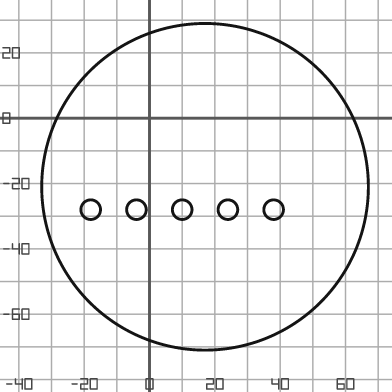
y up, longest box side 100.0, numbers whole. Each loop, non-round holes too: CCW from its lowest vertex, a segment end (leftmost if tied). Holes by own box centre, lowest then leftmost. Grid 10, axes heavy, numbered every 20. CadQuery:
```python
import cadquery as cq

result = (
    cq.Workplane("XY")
    .moveTo(17.0, -21.0)
    .circle(50.0)
    .moveTo(-18.0, -28.0)
    .circle(3.0)
    .moveTo(-4.0, -28.0)
    .circle(3.0)
    .moveTo(10.0, -28.0)
    .circle(3.0)
    .moveTo(24.0, -28.0)
    .circle(3.0)
    .moveTo(38.0, -28.0)
    .circle(3.0)
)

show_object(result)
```